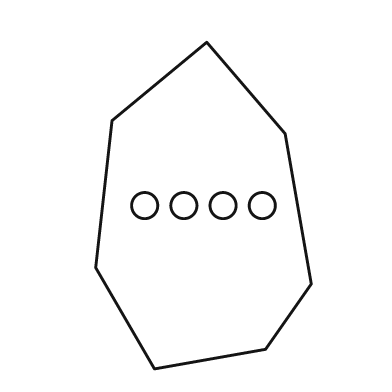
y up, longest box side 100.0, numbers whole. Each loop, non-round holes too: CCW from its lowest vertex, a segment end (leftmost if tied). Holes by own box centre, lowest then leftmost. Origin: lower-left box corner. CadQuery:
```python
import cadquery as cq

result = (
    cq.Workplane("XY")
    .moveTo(18.0, 0.0)
    .lineTo(52.0, 6.0)
    .lineTo(66.0, 26.0)
    .lineTo(58.0, 72.0)
    .lineTo(34.0, 100.0)
    .lineTo(5.0, 76.0)
    .lineTo(0.0, 31.0)
    .close()
    .moveTo(15.0, 50.0)
    .circle(4.0)
    .moveTo(27.0, 50.0)
    .circle(4.0)
    .moveTo(39.0, 50.0)
    .circle(4.0)
    .moveTo(51.0, 50.0)
    .circle(4.0)
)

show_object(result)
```